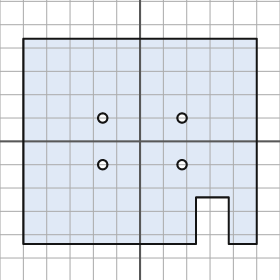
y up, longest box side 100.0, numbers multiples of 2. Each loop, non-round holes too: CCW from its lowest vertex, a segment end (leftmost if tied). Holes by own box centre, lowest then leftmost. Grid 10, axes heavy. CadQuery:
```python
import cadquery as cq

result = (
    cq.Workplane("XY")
    .moveTo(-50.0, -44.0)
    .lineTo(24.0, -44.0)
    .lineTo(24.0, -24.0)
    .lineTo(38.0, -24.0)
    .lineTo(38.0, -44.0)
    .lineTo(50.0, -44.0)
    .lineTo(50.0, 44.0)
    .lineTo(-50.0, 44.0)
    .close()
    .moveTo(-16.0, -10.0)
    .circle(2.0)
    .moveTo(18.0, -10.0)
    .circle(2.0)
    .moveTo(-16.0, 10.0)
    .circle(2.0)
    .moveTo(18.0, 10.0)
    .circle(2.0)
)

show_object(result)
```